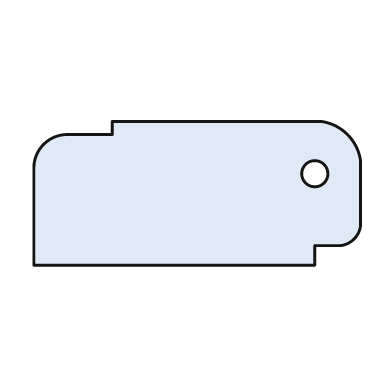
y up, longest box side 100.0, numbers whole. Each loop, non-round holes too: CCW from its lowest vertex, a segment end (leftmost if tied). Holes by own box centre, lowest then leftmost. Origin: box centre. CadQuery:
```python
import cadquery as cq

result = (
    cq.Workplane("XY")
    .moveTo(-50.0, -22.0)
    .lineTo(36.0, -22.0)
    .lineTo(36.0, -16.0)
    .lineTo(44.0, -16.0)
    .threePointArc((48.0, -14.0), (50.0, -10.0))
    .lineTo(50.0, 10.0)
    .threePointArc((46.0, 18.0), (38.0, 22.0))
    .lineTo(-26.0, 22.0)
    .lineTo(-26.0, 18.0)
    .lineTo(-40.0, 18.0)
    .threePointArc((-47.0, 15.0), (-50.0, 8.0))
    .close()
    .moveTo(36.0, 6.0)
    .circle(4.0)
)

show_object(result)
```